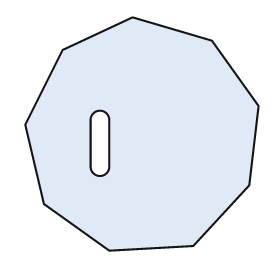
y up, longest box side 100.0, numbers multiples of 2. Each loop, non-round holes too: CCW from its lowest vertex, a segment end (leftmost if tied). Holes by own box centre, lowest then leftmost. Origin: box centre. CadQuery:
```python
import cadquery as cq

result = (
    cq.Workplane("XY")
    .moveTo(-14.0, -50.0)
    .lineTo(22.0, -48.0)
    .lineTo(46.0, -22.0)
    .lineTo(50.0, 12.0)
    .lineTo(30.0, 40.0)
    .lineTo(-4.0, 50.0)
    .lineTo(-34.0, 36.0)
    .lineTo(-50.0, 4.0)
    .lineTo(-42.0, -30.0)
    .close()
    .moveTo(-22.0, -14.0)
    .threePointArc((-18.0, -18.0), (-14.0, -14.0))
    .lineTo(-14.0, 6.0)
    .threePointArc((-18.0, 10.0), (-22.0, 6.0))
    .close()
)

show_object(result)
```